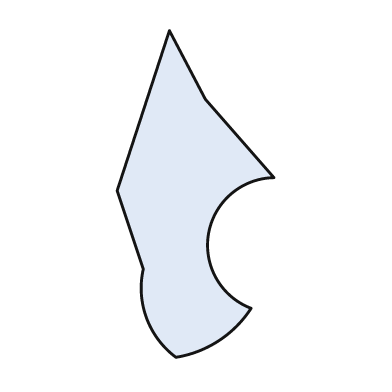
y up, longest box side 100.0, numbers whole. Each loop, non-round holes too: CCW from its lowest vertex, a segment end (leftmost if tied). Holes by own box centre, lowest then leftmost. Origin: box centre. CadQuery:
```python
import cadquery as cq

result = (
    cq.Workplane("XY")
    .moveTo(-6.0, -50.0)
    .threePointArc((7.0, -45.0), (17.0, -35.0))
    .threePointArc((4.0, -12.0), (24.0, 5.0))
    .lineTo(3.0, 29.0)
    .lineTo(-8.0, 50.0)
    .lineTo(-24.0, 1.0)
    .lineTo(-16.0, -23.0)
    .threePointArc((-15.0, -38.0), (-6.0, -50.0))
    .close()
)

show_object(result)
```